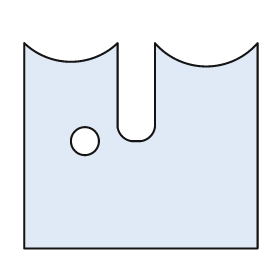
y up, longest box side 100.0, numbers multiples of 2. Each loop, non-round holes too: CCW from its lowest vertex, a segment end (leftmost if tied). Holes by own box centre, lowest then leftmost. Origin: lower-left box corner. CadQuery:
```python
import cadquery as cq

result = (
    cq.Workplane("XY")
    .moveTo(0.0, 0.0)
    .lineTo(100.0, 0.0)
    .lineTo(100.0, 88.0)
    .threePointArc((78.0, 78.0), (56.0, 88.0))
    .lineTo(56.0, 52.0)
    .threePointArc((54.0, 48.0), (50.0, 46.0))
    .lineTo(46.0, 46.0)
    .threePointArc((42.0, 48.0), (40.0, 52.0))
    .lineTo(40.0, 88.0)
    .threePointArc((20.0, 80.0), (0.0, 88.0))
    .close()
    .moveTo(26.0, 46.0)
    .circle(6.0)
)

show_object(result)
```